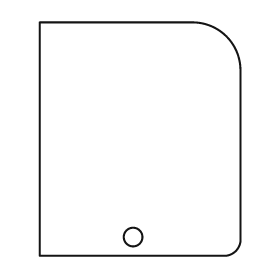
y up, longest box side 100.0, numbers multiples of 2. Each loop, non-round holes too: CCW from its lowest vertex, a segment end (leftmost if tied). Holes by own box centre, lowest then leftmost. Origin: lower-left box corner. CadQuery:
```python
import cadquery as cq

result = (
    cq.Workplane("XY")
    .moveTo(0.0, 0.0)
    .lineTo(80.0, 0.0)
    .threePointArc((84.0, 2.0), (86.0, 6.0))
    .lineTo(86.0, 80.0)
    .threePointArc((80.0, 94.0), (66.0, 100.0))
    .lineTo(0.0, 100.0)
    .close()
    .moveTo(40.0, 8.0)
    .circle(4.0)
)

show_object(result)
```